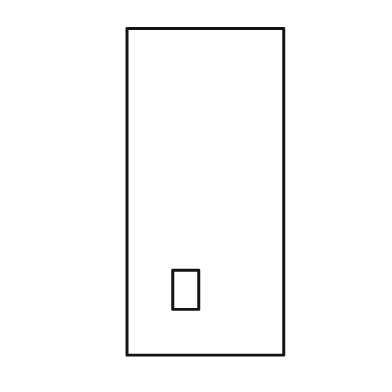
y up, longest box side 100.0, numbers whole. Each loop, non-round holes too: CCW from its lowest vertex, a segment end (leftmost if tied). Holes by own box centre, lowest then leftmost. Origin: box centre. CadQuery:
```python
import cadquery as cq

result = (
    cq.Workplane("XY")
    .moveTo(-24.0, -50.0)
    .lineTo(24.0, -50.0)
    .lineTo(24.0, 50.0)
    .lineTo(-24.0, 50.0)
    .close()
    .moveTo(-10.0, -36.0)
    .lineTo(-2.0, -36.0)
    .lineTo(-2.0, -24.0)
    .lineTo(-10.0, -24.0)
    .close()
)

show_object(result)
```